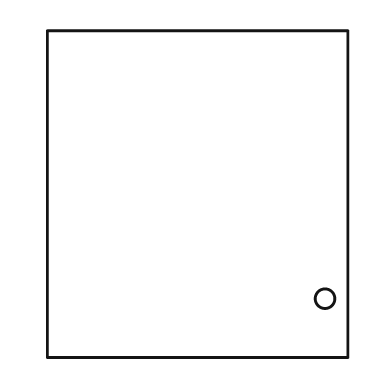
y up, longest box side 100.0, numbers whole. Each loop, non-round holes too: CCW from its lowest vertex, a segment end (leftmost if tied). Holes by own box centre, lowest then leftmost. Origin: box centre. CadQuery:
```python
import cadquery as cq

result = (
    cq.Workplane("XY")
    .moveTo(-46.0, -50.0)
    .lineTo(46.0, -50.0)
    .lineTo(46.0, 50.0)
    .lineTo(-46.0, 50.0)
    .close()
    .moveTo(39.0, -32.0)
    .circle(3.0)
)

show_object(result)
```